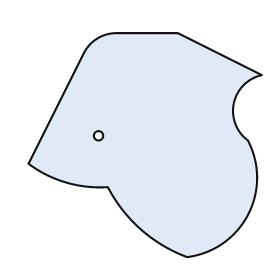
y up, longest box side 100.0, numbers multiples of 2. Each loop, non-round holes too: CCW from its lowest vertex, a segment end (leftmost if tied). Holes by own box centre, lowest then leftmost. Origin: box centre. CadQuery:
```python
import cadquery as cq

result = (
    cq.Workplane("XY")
    .moveTo(18.0, -48.0)
    .threePointArc((44.0, -30.0), (44.0, 2.0))
    .threePointArc((38.0, 18.0), (50.0, 30.0))
    .lineTo(14.0, 48.0)
    .lineTo(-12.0, 48.0)
    .threePointArc((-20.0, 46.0), (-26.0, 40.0))
    .lineTo(-50.0, -8.0)
    .threePointArc((-34.0, -16.0), (-16.0, -18.0))
    .threePointArc((-2.0, -36.0), (18.0, -48.0))
    .close()
    .moveTo(-20.0, 4.0)
    .circle(2.0)
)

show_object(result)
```